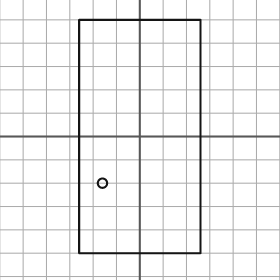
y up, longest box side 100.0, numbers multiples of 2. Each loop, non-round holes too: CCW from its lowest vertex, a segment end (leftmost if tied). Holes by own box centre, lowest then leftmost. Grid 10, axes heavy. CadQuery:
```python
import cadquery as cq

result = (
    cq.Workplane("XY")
    .moveTo(-26.0, -50.0)
    .lineTo(26.0, -50.0)
    .lineTo(26.0, 50.0)
    .lineTo(-26.0, 50.0)
    .close()
    .moveTo(-16.0, -20.0)
    .circle(2.0)
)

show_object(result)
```